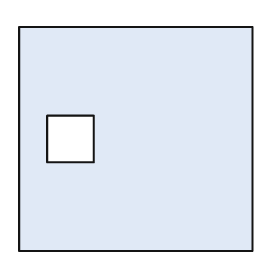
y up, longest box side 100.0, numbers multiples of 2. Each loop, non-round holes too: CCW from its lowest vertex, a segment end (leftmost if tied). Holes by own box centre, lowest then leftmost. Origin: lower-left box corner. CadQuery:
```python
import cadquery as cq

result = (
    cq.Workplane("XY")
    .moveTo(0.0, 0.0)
    .lineTo(100.0, 0.0)
    .lineTo(100.0, 96.0)
    .lineTo(0.0, 96.0)
    .close()
    .moveTo(12.0, 38.0)
    .lineTo(32.0, 38.0)
    .lineTo(32.0, 58.0)
    .lineTo(12.0, 58.0)
    .close()
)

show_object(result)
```